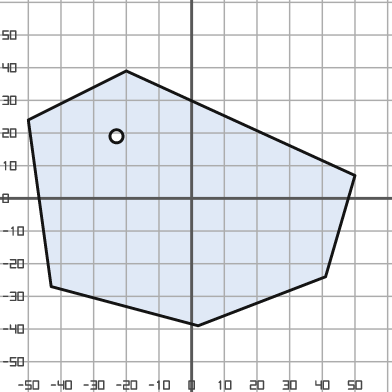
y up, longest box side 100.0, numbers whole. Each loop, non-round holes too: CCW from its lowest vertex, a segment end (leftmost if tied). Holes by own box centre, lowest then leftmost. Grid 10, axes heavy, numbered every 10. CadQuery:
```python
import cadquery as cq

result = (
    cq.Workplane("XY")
    .moveTo(2.0, -39.0)
    .lineTo(41.0, -24.0)
    .lineTo(50.0, 7.0)
    .lineTo(-20.0, 39.0)
    .lineTo(-50.0, 24.0)
    .lineTo(-43.0, -27.0)
    .close()
    .moveTo(-23.0, 19.0)
    .circle(2.0)
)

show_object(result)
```